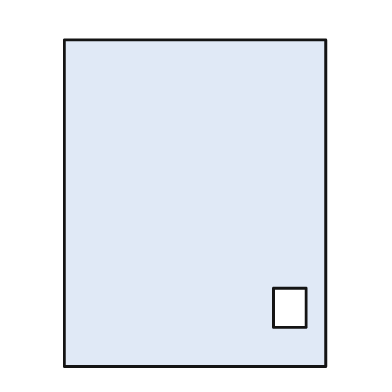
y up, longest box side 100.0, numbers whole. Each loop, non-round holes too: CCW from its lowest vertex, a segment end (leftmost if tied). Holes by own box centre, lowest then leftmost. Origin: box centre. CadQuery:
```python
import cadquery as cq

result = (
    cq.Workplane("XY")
    .moveTo(-40.0, -50.0)
    .lineTo(40.0, -50.0)
    .lineTo(40.0, 50.0)
    .lineTo(-40.0, 50.0)
    .close()
    .moveTo(24.0, -38.0)
    .lineTo(34.0, -38.0)
    .lineTo(34.0, -26.0)
    .lineTo(24.0, -26.0)
    .close()
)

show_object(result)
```